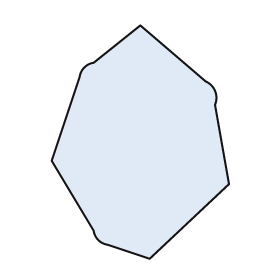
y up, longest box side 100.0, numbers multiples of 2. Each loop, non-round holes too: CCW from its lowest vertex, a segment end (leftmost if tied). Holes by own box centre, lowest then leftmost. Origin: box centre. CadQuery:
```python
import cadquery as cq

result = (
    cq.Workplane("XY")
    .moveTo(4.0, -50.0)
    .lineTo(38.0, -18.0)
    .lineTo(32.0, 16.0)
    .threePointArc((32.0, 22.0), (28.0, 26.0))
    .lineTo(0.0, 50.0)
    .lineTo(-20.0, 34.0)
    .threePointArc((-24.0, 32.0), (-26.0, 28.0))
    .lineTo(-38.0, -8.0)
    .lineTo(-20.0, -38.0)
    .threePointArc((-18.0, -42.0), (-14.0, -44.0))
    .close()
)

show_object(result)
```